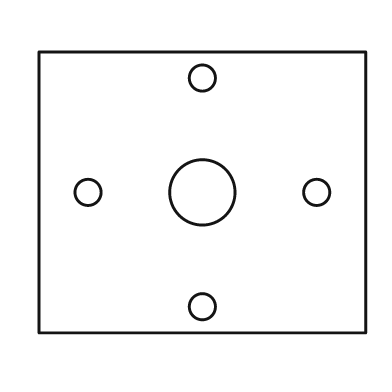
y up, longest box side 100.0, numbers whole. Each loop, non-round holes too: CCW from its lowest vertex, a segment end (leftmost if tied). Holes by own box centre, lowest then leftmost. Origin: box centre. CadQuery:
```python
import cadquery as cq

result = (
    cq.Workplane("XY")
    .moveTo(-50.0, -43.0)
    .lineTo(50.0, -43.0)
    .lineTo(50.0, 43.0)
    .lineTo(-50.0, 43.0)
    .close()
    .moveTo(0.0, -35.0)
    .circle(4.0)
    .moveTo(-35.0, 0.0)
    .circle(4.0)
    .moveTo(0.0, 0.0)
    .circle(10.0)
    .moveTo(35.0, 0.0)
    .circle(4.0)
    .moveTo(0.0, 35.0)
    .circle(4.0)
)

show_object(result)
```